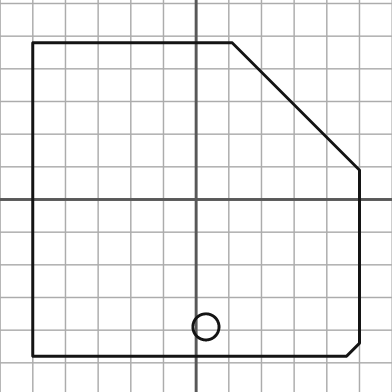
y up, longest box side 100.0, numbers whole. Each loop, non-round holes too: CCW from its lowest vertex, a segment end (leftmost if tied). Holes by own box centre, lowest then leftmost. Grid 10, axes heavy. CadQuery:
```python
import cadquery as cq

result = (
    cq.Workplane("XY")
    .moveTo(-50.0, -48.0)
    .lineTo(46.0, -48.0)
    .lineTo(50.0, -44.0)
    .lineTo(50.0, 9.0)
    .lineTo(11.0, 48.0)
    .lineTo(-50.0, 48.0)
    .close()
    .moveTo(3.0, -39.0)
    .circle(4.0)
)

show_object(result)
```